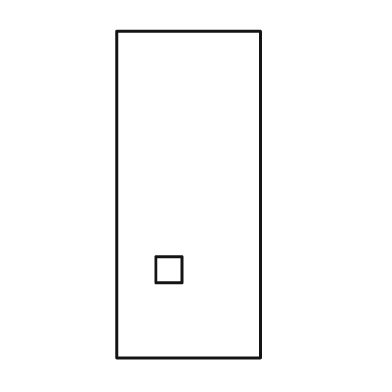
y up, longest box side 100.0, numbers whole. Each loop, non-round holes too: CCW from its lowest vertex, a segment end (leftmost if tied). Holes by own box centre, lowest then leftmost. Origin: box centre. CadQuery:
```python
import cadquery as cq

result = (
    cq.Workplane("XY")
    .moveTo(-22.0, -50.0)
    .lineTo(22.0, -50.0)
    .lineTo(22.0, 50.0)
    .lineTo(-22.0, 50.0)
    .close()
    .moveTo(-10.0, -27.0)
    .lineTo(-2.0, -27.0)
    .lineTo(-2.0, -19.0)
    .lineTo(-10.0, -19.0)
    .close()
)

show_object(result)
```